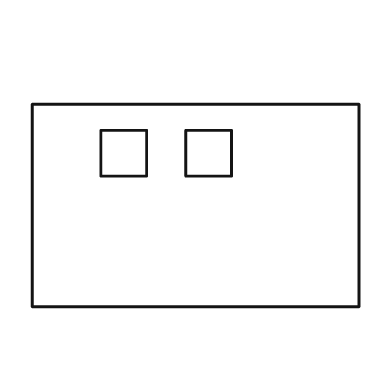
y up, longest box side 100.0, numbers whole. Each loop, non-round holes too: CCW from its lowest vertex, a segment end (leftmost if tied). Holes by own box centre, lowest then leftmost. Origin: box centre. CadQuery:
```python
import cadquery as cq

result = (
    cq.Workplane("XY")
    .moveTo(-50.0, -31.0)
    .lineTo(50.0, -31.0)
    .lineTo(50.0, 31.0)
    .lineTo(-50.0, 31.0)
    .close()
    .moveTo(-29.0, 9.0)
    .lineTo(-15.0, 9.0)
    .lineTo(-15.0, 23.0)
    .lineTo(-29.0, 23.0)
    .close()
    .moveTo(-3.0, 9.0)
    .lineTo(11.0, 9.0)
    .lineTo(11.0, 23.0)
    .lineTo(-3.0, 23.0)
    .close()
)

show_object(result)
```